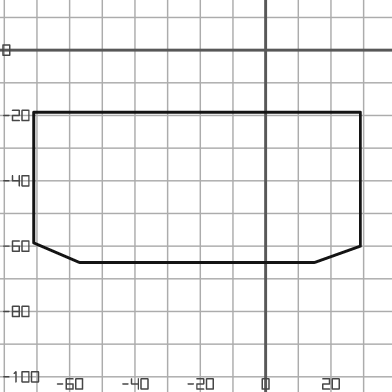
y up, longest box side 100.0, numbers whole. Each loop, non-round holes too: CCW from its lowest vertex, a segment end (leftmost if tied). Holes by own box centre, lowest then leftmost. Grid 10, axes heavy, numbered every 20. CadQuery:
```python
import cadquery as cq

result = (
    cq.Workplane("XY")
    .moveTo(-57.0, -65.0)
    .lineTo(15.0, -65.0)
    .lineTo(29.0, -60.0)
    .lineTo(29.0, -19.0)
    .lineTo(-71.0, -19.0)
    .lineTo(-71.0, -59.0)
    .close()
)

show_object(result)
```